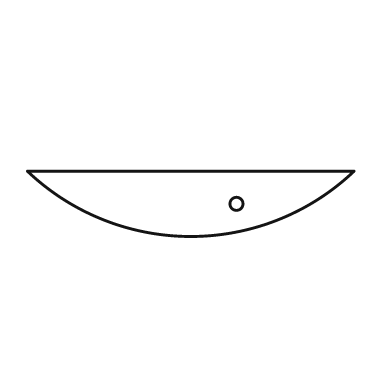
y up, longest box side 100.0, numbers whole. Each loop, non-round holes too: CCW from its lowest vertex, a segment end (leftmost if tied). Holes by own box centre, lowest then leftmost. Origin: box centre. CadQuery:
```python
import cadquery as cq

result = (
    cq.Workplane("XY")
    .moveTo(-50.0, 10.0)
    .threePointArc((0.0, -10.0), (50.0, 10.0))
    .close()
    .moveTo(14.0, 0.0)
    .circle(2.0)
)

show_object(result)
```